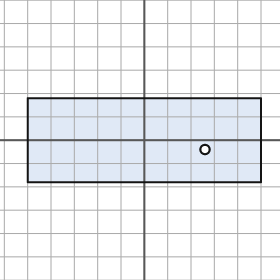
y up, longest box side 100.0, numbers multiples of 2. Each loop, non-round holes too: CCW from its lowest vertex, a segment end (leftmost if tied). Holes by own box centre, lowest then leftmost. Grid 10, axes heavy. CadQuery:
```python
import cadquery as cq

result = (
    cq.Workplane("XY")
    .moveTo(-50.0, -18.0)
    .lineTo(50.0, -18.0)
    .lineTo(50.0, 18.0)
    .lineTo(-50.0, 18.0)
    .close()
    .moveTo(26.0, -4.0)
    .circle(2.0)
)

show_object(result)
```